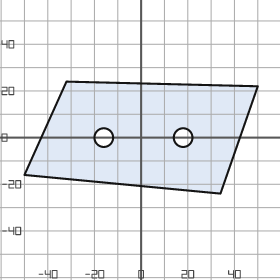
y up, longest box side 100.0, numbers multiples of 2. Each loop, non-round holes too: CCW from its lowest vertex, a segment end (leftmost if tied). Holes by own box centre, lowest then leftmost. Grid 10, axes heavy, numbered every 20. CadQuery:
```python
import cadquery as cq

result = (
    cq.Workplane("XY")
    .moveTo(34.0, -24.0)
    .lineTo(50.0, 22.0)
    .lineTo(-32.0, 24.0)
    .lineTo(-50.0, -16.0)
    .close()
    .moveTo(-16.0, 0.0)
    .circle(4.0)
    .moveTo(18.0, 0.0)
    .circle(4.0)
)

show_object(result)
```